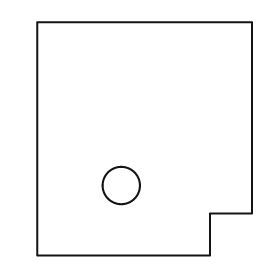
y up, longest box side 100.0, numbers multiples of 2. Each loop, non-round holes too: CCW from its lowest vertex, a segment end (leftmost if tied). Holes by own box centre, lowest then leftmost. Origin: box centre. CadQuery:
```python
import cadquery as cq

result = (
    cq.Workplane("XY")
    .moveTo(-46.0, -50.0)
    .lineTo(28.0, -50.0)
    .lineTo(28.0, -32.0)
    .lineTo(46.0, -32.0)
    .lineTo(46.0, 50.0)
    .lineTo(-46.0, 50.0)
    .close()
    .moveTo(-10.0, -20.0)
    .circle(8.0)
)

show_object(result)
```